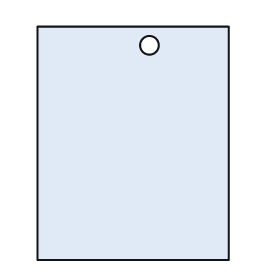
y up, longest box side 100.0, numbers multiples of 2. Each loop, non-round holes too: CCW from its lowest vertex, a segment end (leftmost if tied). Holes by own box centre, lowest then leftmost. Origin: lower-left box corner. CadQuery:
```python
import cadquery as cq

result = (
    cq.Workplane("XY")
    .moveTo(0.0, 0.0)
    .lineTo(82.0, 0.0)
    .lineTo(82.0, 100.0)
    .lineTo(0.0, 100.0)
    .close()
    .moveTo(48.0, 92.0)
    .circle(4.0)
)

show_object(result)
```